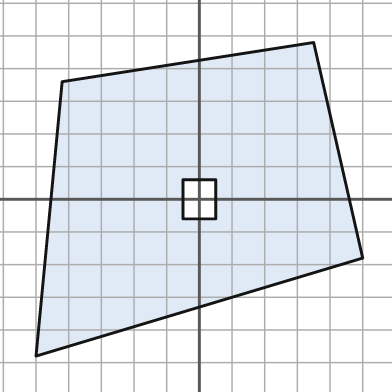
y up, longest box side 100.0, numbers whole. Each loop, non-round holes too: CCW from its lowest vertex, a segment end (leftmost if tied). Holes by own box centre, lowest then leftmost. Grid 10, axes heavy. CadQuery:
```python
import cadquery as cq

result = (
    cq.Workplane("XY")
    .moveTo(-50.0, -48.0)
    .lineTo(50.0, -18.0)
    .lineTo(35.0, 48.0)
    .lineTo(-42.0, 36.0)
    .close()
    .moveTo(-5.0, -6.0)
    .lineTo(5.0, -6.0)
    .lineTo(5.0, 6.0)
    .lineTo(-5.0, 6.0)
    .close()
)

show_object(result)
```